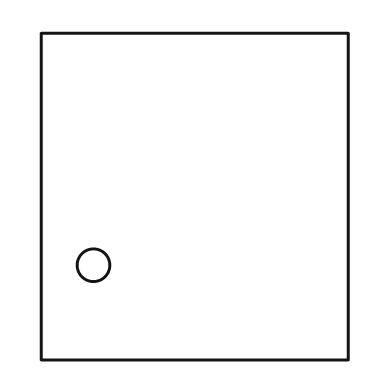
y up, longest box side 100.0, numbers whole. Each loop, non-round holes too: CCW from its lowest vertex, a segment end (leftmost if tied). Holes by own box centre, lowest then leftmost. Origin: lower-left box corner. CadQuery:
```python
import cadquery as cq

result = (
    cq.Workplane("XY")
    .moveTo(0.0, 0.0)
    .lineTo(94.0, 0.0)
    .lineTo(94.0, 100.0)
    .lineTo(0.0, 100.0)
    .close()
    .moveTo(16.0, 29.0)
    .circle(5.0)
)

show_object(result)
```